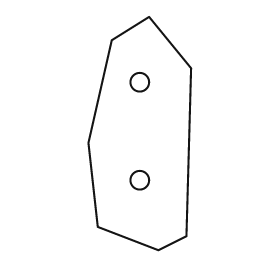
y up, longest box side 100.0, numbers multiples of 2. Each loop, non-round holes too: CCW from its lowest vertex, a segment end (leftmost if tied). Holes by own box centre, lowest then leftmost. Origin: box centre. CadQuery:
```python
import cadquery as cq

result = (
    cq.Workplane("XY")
    .moveTo(8.0, -50.0)
    .lineTo(20.0, -44.0)
    .lineTo(22.0, 28.0)
    .lineTo(4.0, 50.0)
    .lineTo(-12.0, 40.0)
    .lineTo(-22.0, -4.0)
    .lineTo(-18.0, -40.0)
    .close()
    .moveTo(0.0, -20.0)
    .circle(4.0)
    .moveTo(0.0, 22.0)
    .circle(4.0)
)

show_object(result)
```